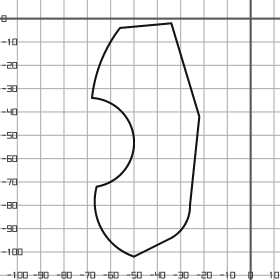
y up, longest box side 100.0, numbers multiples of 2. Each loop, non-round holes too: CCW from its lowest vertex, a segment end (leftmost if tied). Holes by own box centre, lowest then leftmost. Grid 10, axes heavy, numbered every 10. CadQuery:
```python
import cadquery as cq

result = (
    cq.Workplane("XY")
    .moveTo(-50.0, -102.0)
    .lineTo(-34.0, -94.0)
    .threePointArc((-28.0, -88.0), (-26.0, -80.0))
    .lineTo(-22.0, -42.0)
    .lineTo(-34.0, -2.0)
    .lineTo(-56.0, -4.0)
    .threePointArc((-64.0, -18.0), (-68.0, -34.0))
    .threePointArc((-50.0, -52.0), (-66.0, -72.0))
    .threePointArc((-64.0, -90.0), (-50.0, -102.0))
    .close()
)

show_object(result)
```